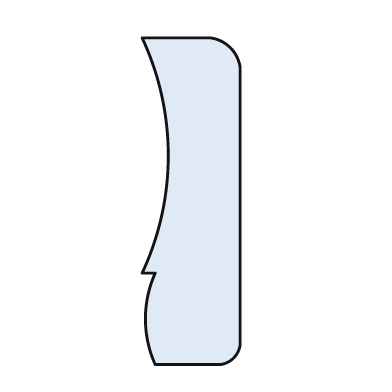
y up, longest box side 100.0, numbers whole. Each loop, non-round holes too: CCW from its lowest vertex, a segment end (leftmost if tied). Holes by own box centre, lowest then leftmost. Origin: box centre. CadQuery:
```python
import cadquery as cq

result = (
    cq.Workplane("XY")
    .moveTo(-11.0, -50.0)
    .lineTo(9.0, -50.0)
    .threePointArc((13.0, -48.0), (15.0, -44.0))
    .lineTo(15.0, 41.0)
    .threePointArc((12.0, 47.0), (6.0, 50.0))
    .lineTo(-15.0, 50.0)
    .threePointArc((-7.0, 14.0), (-15.0, -22.0))
    .lineTo(-11.0, -22.0)
    .threePointArc((-14.0, -36.0), (-11.0, -50.0))
    .close()
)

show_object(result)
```